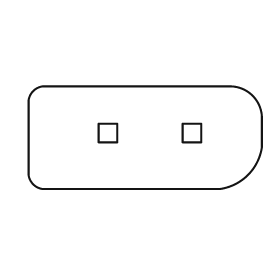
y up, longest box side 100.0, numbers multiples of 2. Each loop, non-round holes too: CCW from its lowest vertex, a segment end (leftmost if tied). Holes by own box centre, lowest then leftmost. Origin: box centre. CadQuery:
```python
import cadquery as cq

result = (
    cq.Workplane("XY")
    .moveTo(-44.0, -22.0)
    .lineTo(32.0, -22.0)
    .threePointArc((44.0, -16.0), (50.0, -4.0))
    .lineTo(50.0, 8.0)
    .threePointArc((46.0, 18.0), (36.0, 22.0))
    .lineTo(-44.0, 22.0)
    .threePointArc((-48.0, 20.0), (-50.0, 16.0))
    .lineTo(-50.0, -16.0)
    .threePointArc((-48.0, -20.0), (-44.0, -22.0))
    .close()
    .moveTo(-20.0, -2.0)
    .lineTo(-12.0, -2.0)
    .lineTo(-12.0, 6.0)
    .lineTo(-20.0, 6.0)
    .close()
    .moveTo(16.0, -2.0)
    .lineTo(24.0, -2.0)
    .lineTo(24.0, 6.0)
    .lineTo(16.0, 6.0)
    .close()
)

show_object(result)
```